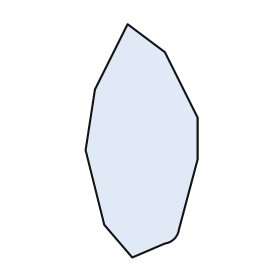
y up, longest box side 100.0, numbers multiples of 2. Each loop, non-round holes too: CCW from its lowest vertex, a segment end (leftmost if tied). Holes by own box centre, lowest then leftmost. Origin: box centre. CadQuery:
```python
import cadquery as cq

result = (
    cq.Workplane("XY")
    .moveTo(-4.0, -50.0)
    .lineTo(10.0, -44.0)
    .threePointArc((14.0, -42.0), (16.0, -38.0))
    .lineTo(24.0, -8.0)
    .lineTo(24.0, 10.0)
    .lineTo(10.0, 38.0)
    .lineTo(-6.0, 50.0)
    .lineTo(-20.0, 22.0)
    .lineTo(-24.0, -4.0)
    .lineTo(-16.0, -36.0)
    .close()
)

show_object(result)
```